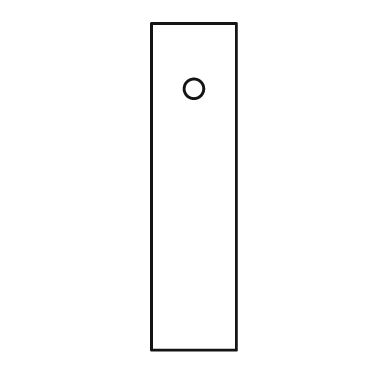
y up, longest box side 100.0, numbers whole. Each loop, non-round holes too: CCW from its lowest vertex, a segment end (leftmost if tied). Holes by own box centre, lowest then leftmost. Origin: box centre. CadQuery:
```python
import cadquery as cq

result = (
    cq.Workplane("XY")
    .moveTo(-13.0, -50.0)
    .lineTo(13.0, -50.0)
    .lineTo(13.0, 50.0)
    .lineTo(-13.0, 50.0)
    .close()
    .moveTo(0.0, 30.0)
    .circle(3.0)
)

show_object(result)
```